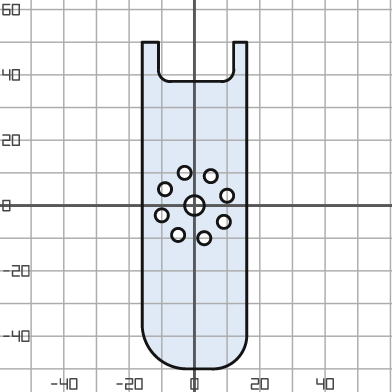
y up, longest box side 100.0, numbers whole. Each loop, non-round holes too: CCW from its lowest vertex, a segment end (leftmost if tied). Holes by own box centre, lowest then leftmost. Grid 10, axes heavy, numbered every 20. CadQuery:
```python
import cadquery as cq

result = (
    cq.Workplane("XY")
    .moveTo(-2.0, -50.0)
    .lineTo(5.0, -50.0)
    .threePointArc((13.0, -47.0), (16.0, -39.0))
    .lineTo(16.0, 50.0)
    .lineTo(12.0, 50.0)
    .lineTo(12.0, 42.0)
    .threePointArc((11.0, 39.0), (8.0, 38.0))
    .lineTo(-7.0, 38.0)
    .threePointArc((-10.0, 39.0), (-11.0, 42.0))
    .lineTo(-11.0, 50.0)
    .lineTo(-16.0, 50.0)
    .lineTo(-16.0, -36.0)
    .threePointArc((-12.0, -46.0), (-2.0, -50.0))
    .close()
    .moveTo(3.0, -10.0)
    .circle(2.0)
    .moveTo(-5.0, -9.0)
    .circle(2.0)
    .moveTo(9.0, -5.0)
    .circle(2.0)
    .moveTo(-10.0, -3.0)
    .circle(2.0)
    .moveTo(0.0, 0.0)
    .circle(3.0)
    .moveTo(10.0, 3.0)
    .circle(2.0)
    .moveTo(-9.0, 5.0)
    .circle(2.0)
    .moveTo(5.0, 9.0)
    .circle(2.0)
    .moveTo(-3.0, 10.0)
    .circle(2.0)
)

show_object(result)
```